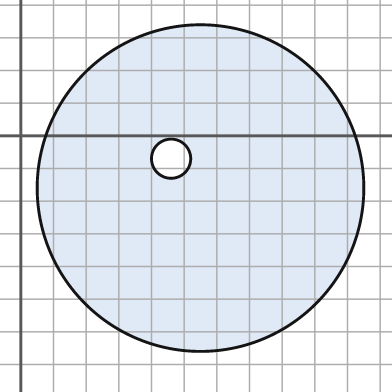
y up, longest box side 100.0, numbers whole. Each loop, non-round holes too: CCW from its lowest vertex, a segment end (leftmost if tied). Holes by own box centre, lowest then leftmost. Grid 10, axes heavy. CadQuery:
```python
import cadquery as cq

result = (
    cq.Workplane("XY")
    .moveTo(55.0, -16.0)
    .circle(50.0)
    .moveTo(46.0, -7.0)
    .circle(6.0)
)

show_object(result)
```